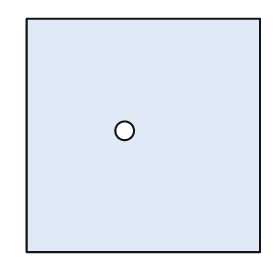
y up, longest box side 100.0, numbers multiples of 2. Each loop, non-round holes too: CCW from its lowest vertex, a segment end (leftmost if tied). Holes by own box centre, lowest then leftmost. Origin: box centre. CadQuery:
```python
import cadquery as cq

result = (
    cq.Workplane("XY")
    .moveTo(-50.0, -50.0)
    .lineTo(50.0, -50.0)
    .lineTo(50.0, 50.0)
    .lineTo(-50.0, 50.0)
    .close()
    .moveTo(-8.0, 2.0)
    .circle(4.0)
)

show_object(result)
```